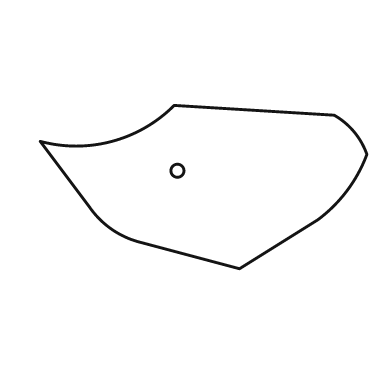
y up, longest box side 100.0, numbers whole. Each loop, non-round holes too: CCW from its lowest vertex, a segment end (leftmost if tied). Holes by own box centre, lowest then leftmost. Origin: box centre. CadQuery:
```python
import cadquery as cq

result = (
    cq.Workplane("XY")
    .moveTo(11.0, -25.0)
    .lineTo(35.0, -10.0)
    .threePointArc((44.0, -1.0), (50.0, 10.0))
    .threePointArc((46.0, 17.0), (40.0, 22.0))
    .lineTo(-9.0, 25.0)
    .threePointArc((-28.0, 14.0), (-50.0, 14.0))
    .lineTo(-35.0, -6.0)
    .threePointArc((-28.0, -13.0), (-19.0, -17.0))
    .close()
    .moveTo(-8.0, 5.0)
    .circle(2.0)
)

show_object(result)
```